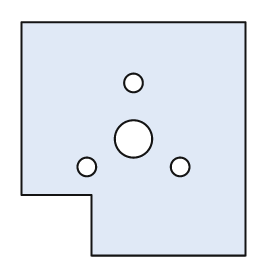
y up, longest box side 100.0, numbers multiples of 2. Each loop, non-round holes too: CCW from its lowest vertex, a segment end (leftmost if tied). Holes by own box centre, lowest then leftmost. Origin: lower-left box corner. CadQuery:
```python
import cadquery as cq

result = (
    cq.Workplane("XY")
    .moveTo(30.0, 0.0)
    .lineTo(96.0, 0.0)
    .lineTo(96.0, 100.0)
    .lineTo(0.0, 100.0)
    .lineTo(0.0, 26.0)
    .lineTo(30.0, 26.0)
    .close()
    .moveTo(28.0, 38.0)
    .circle(4.0)
    .moveTo(68.0, 38.0)
    .circle(4.0)
    .moveTo(48.0, 50.0)
    .circle(8.0)
    .moveTo(48.0, 74.0)
    .circle(4.0)
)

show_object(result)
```